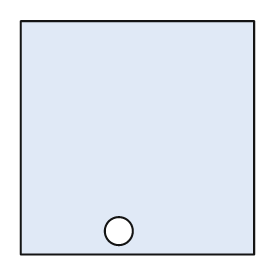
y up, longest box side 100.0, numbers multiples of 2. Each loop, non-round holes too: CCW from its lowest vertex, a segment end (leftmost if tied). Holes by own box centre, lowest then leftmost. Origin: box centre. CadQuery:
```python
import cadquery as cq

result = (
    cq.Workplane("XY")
    .moveTo(-50.0, -50.0)
    .lineTo(50.0, -50.0)
    .lineTo(50.0, 50.0)
    .lineTo(-50.0, 50.0)
    .close()
    .moveTo(-8.0, -40.0)
    .circle(6.0)
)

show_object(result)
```